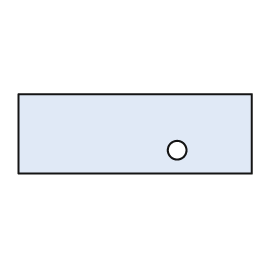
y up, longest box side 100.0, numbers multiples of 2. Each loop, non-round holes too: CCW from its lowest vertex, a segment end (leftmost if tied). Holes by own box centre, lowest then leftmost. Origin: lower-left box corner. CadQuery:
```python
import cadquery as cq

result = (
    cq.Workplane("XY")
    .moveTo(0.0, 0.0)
    .lineTo(100.0, 0.0)
    .lineTo(100.0, 34.0)
    .lineTo(0.0, 34.0)
    .close()
    .moveTo(68.0, 10.0)
    .circle(4.0)
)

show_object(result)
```